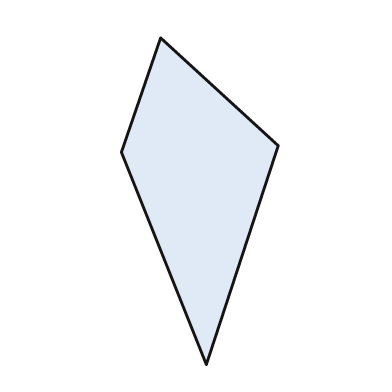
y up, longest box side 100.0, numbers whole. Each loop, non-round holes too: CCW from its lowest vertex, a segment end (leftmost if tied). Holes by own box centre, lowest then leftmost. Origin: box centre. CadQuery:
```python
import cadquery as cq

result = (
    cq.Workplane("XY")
    .moveTo(2.0, -50.0)
    .lineTo(24.0, 17.0)
    .lineTo(-12.0, 50.0)
    .lineTo(-24.0, 15.0)
    .close()
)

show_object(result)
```